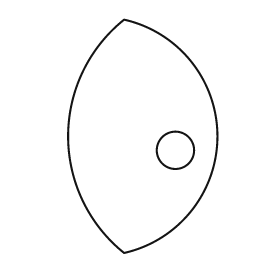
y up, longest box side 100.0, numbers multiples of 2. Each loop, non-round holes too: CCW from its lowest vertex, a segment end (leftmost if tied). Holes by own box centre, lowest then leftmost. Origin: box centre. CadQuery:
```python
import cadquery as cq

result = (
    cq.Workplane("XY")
    .moveTo(-8.0, -50.0)
    .threePointArc((32.0, 0.0), (-8.0, 50.0))
    .threePointArc((-32.0, 0.0), (-8.0, -50.0))
    .close()
    .moveTo(14.0, -6.0)
    .circle(8.0)
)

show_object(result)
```